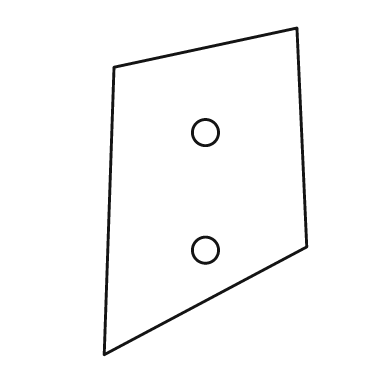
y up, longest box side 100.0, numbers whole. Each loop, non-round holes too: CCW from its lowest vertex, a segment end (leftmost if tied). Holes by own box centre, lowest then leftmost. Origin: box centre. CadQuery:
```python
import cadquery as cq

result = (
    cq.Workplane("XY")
    .moveTo(-31.0, -50.0)
    .lineTo(31.0, -17.0)
    .lineTo(28.0, 50.0)
    .lineTo(-28.0, 38.0)
    .close()
    .moveTo(0.0, -18.0)
    .circle(4.0)
    .moveTo(0.0, 18.0)
    .circle(4.0)
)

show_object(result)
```